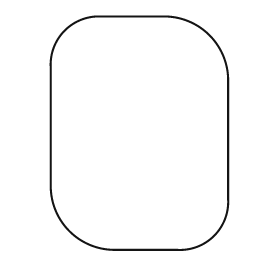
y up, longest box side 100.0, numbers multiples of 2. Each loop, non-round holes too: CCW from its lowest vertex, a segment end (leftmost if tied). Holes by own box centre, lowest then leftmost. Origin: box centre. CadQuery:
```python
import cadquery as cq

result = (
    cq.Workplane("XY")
    .moveTo(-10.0, -50.0)
    .lineTo(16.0, -50.0)
    .threePointArc((32.0, -44.0), (38.0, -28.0))
    .lineTo(38.0, 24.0)
    .threePointArc((30.0, 42.0), (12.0, 50.0))
    .lineTo(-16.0, 50.0)
    .threePointArc((-32.0, 44.0), (-38.0, 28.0))
    .lineTo(-38.0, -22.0)
    .threePointArc((-30.0, -42.0), (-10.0, -50.0))
    .close()
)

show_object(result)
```